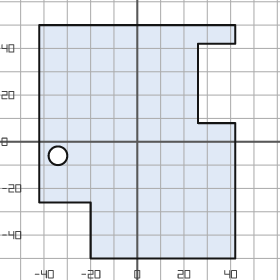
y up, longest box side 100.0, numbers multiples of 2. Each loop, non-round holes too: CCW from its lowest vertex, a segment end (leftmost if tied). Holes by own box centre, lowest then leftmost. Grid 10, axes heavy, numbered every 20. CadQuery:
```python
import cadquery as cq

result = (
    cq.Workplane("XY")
    .moveTo(-20.0, -50.0)
    .lineTo(42.0, -50.0)
    .lineTo(42.0, 8.0)
    .lineTo(26.0, 8.0)
    .lineTo(26.0, 42.0)
    .lineTo(42.0, 42.0)
    .lineTo(42.0, 50.0)
    .lineTo(-42.0, 50.0)
    .lineTo(-42.0, -26.0)
    .lineTo(-20.0, -26.0)
    .close()
    .moveTo(-34.0, -6.0)
    .circle(4.0)
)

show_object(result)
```